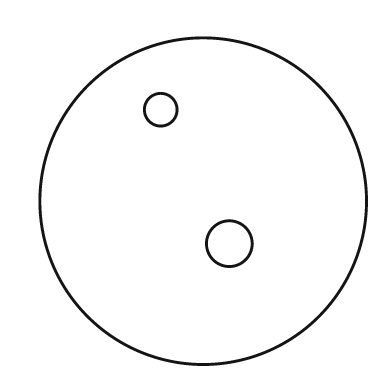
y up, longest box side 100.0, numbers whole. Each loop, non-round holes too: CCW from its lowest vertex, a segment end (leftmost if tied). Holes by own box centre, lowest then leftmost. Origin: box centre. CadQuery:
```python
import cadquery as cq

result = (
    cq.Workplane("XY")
    .moveTo(0.0, 0.0)
    .circle(50.0)
    .moveTo(8.0, -13.0)
    .circle(7.0)
    .moveTo(-13.0, 28.0)
    .circle(5.0)
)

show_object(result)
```